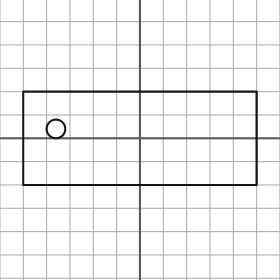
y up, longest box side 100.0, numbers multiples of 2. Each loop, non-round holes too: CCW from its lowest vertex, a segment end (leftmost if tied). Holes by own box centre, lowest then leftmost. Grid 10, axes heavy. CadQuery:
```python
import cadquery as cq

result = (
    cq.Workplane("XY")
    .moveTo(-50.0, -20.0)
    .lineTo(50.0, -20.0)
    .lineTo(50.0, 20.0)
    .lineTo(-50.0, 20.0)
    .close()
    .moveTo(-36.0, 4.0)
    .circle(4.0)
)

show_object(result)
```